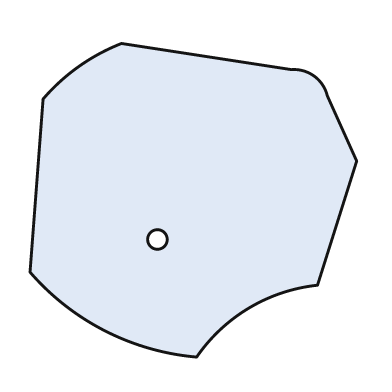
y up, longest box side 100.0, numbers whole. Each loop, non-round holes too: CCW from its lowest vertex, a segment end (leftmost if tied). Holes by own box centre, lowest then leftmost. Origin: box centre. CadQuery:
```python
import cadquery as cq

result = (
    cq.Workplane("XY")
    .moveTo(1.0, -48.0)
    .threePointArc((17.0, -33.0), (38.0, -26.0))
    .lineTo(50.0, 12.0)
    .lineTo(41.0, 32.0)
    .threePointArc((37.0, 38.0), (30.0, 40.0))
    .lineTo(-22.0, 48.0)
    .threePointArc((-35.0, 41.0), (-46.0, 31.0))
    .lineTo(-50.0, -22.0)
    .threePointArc((-27.0, -40.0), (1.0, -48.0))
    .close()
    .moveTo(-11.0, -12.0)
    .circle(3.0)
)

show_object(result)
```